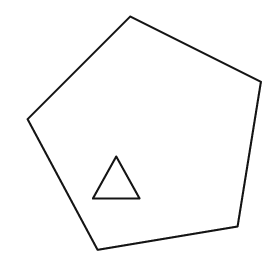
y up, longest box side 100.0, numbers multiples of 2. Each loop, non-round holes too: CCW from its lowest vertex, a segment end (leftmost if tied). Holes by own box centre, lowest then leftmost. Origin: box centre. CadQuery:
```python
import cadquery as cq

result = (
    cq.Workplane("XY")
    .moveTo(-20.0, -50.0)
    .lineTo(40.0, -40.0)
    .lineTo(50.0, 22.0)
    .lineTo(-6.0, 50.0)
    .lineTo(-50.0, 6.0)
    .close()
    .moveTo(-22.0, -28.0)
    .lineTo(-2.0, -28.0)
    .lineTo(-12.0, -10.0)
    .close()
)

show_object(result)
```